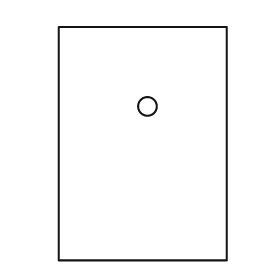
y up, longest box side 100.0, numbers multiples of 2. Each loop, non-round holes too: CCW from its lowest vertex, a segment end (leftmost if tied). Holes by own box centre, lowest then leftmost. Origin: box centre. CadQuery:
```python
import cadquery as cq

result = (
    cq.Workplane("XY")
    .moveTo(-36.0, -50.0)
    .lineTo(36.0, -50.0)
    .lineTo(36.0, 50.0)
    .lineTo(-36.0, 50.0)
    .close()
    .moveTo(2.0, 16.0)
    .circle(4.0)
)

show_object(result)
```